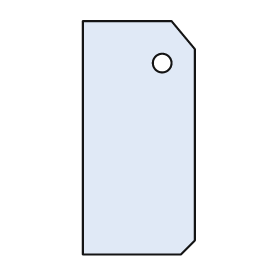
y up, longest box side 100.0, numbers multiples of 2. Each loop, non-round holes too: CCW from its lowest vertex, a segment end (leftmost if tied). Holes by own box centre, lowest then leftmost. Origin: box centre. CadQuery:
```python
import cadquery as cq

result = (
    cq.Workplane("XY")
    .moveTo(-24.0, -50.0)
    .lineTo(18.0, -50.0)
    .lineTo(24.0, -44.0)
    .lineTo(24.0, 38.0)
    .lineTo(14.0, 50.0)
    .lineTo(-24.0, 50.0)
    .close()
    .moveTo(10.0, 32.0)
    .circle(4.0)
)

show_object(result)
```